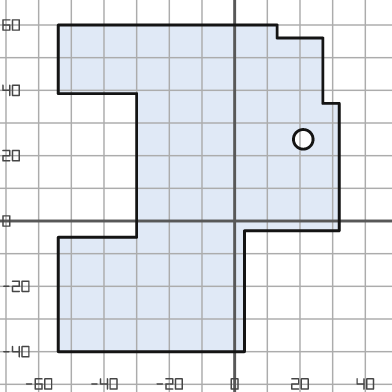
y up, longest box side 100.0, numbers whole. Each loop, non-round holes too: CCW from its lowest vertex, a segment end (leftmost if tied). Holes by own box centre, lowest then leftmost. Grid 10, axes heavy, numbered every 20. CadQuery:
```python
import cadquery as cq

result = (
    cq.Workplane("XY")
    .moveTo(-54.0, -40.0)
    .lineTo(3.0, -40.0)
    .lineTo(3.0, -3.0)
    .lineTo(32.0, -3.0)
    .lineTo(32.0, 36.0)
    .lineTo(27.0, 36.0)
    .lineTo(27.0, 56.0)
    .lineTo(13.0, 56.0)
    .lineTo(13.0, 60.0)
    .lineTo(-54.0, 60.0)
    .lineTo(-54.0, 39.0)
    .lineTo(-30.0, 39.0)
    .lineTo(-30.0, -5.0)
    .lineTo(-54.0, -5.0)
    .close()
    .moveTo(21.0, 25.0)
    .circle(3.0)
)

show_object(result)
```